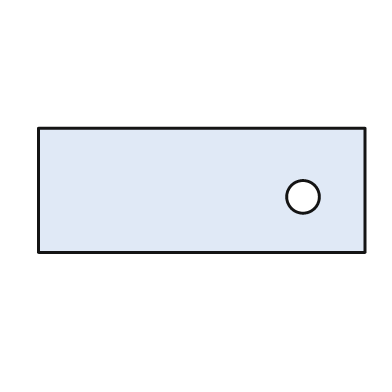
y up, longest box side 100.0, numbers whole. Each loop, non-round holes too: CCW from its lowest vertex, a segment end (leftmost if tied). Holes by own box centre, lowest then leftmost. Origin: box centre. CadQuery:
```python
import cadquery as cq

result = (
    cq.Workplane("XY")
    .moveTo(-50.0, -19.0)
    .lineTo(50.0, -19.0)
    .lineTo(50.0, 19.0)
    .lineTo(-50.0, 19.0)
    .close()
    .moveTo(31.0, -2.0)
    .circle(5.0)
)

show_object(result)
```